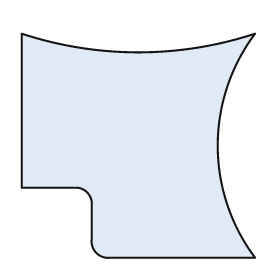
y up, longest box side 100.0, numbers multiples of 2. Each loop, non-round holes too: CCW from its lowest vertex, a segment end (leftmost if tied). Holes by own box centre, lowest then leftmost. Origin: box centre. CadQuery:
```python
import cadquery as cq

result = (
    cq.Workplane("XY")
    .moveTo(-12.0, -48.0)
    .lineTo(50.0, -48.0)
    .threePointArc((34.0, 0.0), (50.0, 48.0))
    .threePointArc((0.0, 40.0), (-50.0, 48.0))
    .lineTo(-50.0, -18.0)
    .lineTo(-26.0, -18.0)
    .threePointArc((-22.0, -20.0), (-20.0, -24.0))
    .lineTo(-20.0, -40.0)
    .threePointArc((-18.0, -46.0), (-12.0, -48.0))
    .close()
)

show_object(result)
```